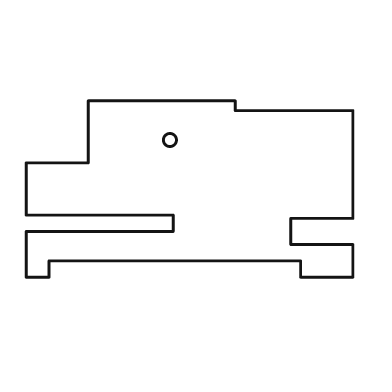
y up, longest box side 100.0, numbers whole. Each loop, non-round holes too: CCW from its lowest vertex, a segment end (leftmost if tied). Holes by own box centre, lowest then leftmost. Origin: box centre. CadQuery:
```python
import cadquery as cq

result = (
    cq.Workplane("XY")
    .moveTo(-50.0, -27.0)
    .lineTo(-43.0, -27.0)
    .lineTo(-43.0, -22.0)
    .lineTo(34.0, -22.0)
    .lineTo(34.0, -27.0)
    .lineTo(50.0, -27.0)
    .lineTo(50.0, -17.0)
    .lineTo(31.0, -17.0)
    .lineTo(31.0, -9.0)
    .lineTo(50.0, -9.0)
    .lineTo(50.0, 24.0)
    .lineTo(14.0, 24.0)
    .lineTo(14.0, 27.0)
    .lineTo(-31.0, 27.0)
    .lineTo(-31.0, 8.0)
    .lineTo(-50.0, 8.0)
    .lineTo(-50.0, -8.0)
    .lineTo(-5.0, -8.0)
    .lineTo(-5.0, -13.0)
    .lineTo(-50.0, -13.0)
    .close()
    .moveTo(-6.0, 15.0)
    .circle(2.0)
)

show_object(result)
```